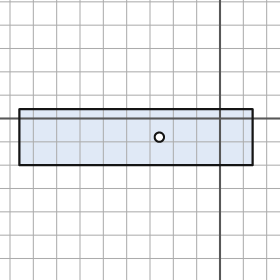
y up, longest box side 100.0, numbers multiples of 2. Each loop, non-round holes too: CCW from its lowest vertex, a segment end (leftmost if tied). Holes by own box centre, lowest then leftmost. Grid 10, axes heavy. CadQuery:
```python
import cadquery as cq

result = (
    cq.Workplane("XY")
    .moveTo(-86.0, -20.0)
    .lineTo(14.0, -20.0)
    .lineTo(14.0, 4.0)
    .lineTo(-86.0, 4.0)
    .close()
    .moveTo(-26.0, -8.0)
    .circle(2.0)
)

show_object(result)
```